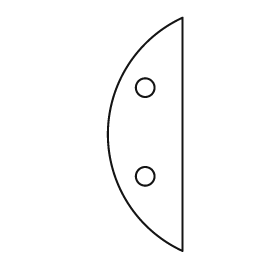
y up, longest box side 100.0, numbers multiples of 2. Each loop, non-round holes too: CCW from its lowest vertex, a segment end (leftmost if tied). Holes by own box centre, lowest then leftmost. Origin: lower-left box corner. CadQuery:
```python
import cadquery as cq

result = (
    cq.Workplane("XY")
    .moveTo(32.0, 0.0)
    .lineTo(32.0, 100.0)
    .threePointArc((0.0, 50.0), (32.0, 0.0))
    .close()
    .moveTo(16.0, 32.0)
    .circle(4.0)
    .moveTo(16.0, 70.0)
    .circle(4.0)
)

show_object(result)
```